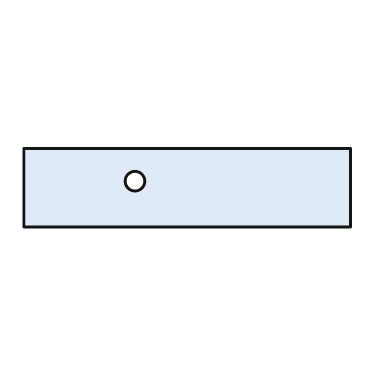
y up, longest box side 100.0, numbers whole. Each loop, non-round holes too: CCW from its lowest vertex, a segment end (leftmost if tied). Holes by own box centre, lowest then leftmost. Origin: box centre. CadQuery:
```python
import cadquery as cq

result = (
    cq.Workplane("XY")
    .moveTo(-50.0, -12.0)
    .lineTo(50.0, -12.0)
    .lineTo(50.0, 12.0)
    .lineTo(-50.0, 12.0)
    .close()
    .moveTo(-16.0, 2.0)
    .circle(3.0)
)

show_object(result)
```